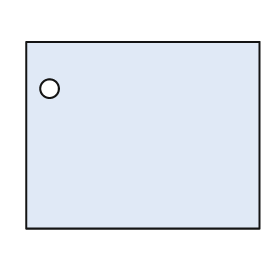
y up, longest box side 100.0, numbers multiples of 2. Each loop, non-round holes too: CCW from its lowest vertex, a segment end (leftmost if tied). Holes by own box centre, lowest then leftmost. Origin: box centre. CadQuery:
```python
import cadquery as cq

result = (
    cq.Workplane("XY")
    .moveTo(-50.0, -40.0)
    .lineTo(50.0, -40.0)
    .lineTo(50.0, 40.0)
    .lineTo(-50.0, 40.0)
    .close()
    .moveTo(-40.0, 20.0)
    .circle(4.0)
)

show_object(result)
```